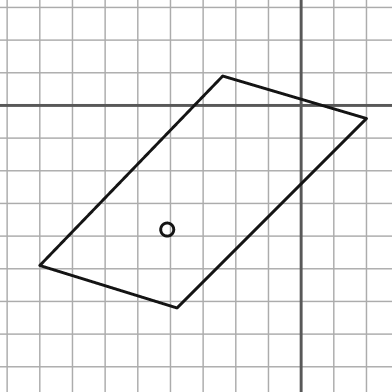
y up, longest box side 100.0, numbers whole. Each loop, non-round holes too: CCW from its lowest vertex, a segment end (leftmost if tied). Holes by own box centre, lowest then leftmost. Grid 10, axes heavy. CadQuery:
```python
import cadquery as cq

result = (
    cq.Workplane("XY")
    .moveTo(-38.0, -62.0)
    .lineTo(20.0, -4.0)
    .lineTo(-24.0, 9.0)
    .lineTo(-80.0, -49.0)
    .close()
    .moveTo(-41.0, -38.0)
    .circle(2.0)
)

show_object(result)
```